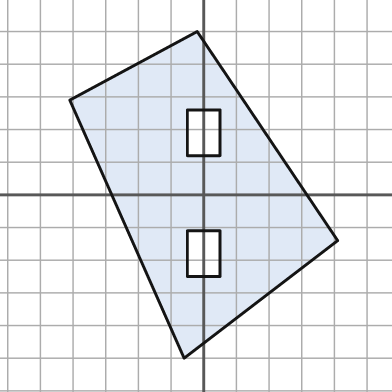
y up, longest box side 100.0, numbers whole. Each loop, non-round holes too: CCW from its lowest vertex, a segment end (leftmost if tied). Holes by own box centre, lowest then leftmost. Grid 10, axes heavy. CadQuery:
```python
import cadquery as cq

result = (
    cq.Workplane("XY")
    .moveTo(-6.0, -50.0)
    .lineTo(41.0, -14.0)
    .lineTo(-2.0, 50.0)
    .lineTo(-41.0, 29.0)
    .close()
    .moveTo(-5.0, -25.0)
    .lineTo(5.0, -25.0)
    .lineTo(5.0, -11.0)
    .lineTo(-5.0, -11.0)
    .close()
    .moveTo(-5.0, 12.0)
    .lineTo(5.0, 12.0)
    .lineTo(5.0, 26.0)
    .lineTo(-5.0, 26.0)
    .close()
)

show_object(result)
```